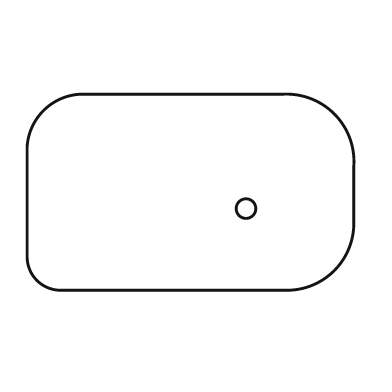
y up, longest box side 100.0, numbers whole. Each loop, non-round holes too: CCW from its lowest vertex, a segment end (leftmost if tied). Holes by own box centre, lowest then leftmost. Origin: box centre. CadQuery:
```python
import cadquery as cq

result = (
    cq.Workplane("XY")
    .moveTo(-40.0, -30.0)
    .lineTo(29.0, -30.0)
    .threePointArc((44.0, -24.0), (50.0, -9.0))
    .lineTo(50.0, 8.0)
    .threePointArc((44.0, 24.0), (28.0, 30.0))
    .lineTo(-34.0, 30.0)
    .threePointArc((-45.0, 25.0), (-50.0, 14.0))
    .lineTo(-50.0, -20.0)
    .threePointArc((-47.0, -27.0), (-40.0, -30.0))
    .close()
    .moveTo(17.0, -5.0)
    .circle(3.0)
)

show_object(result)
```